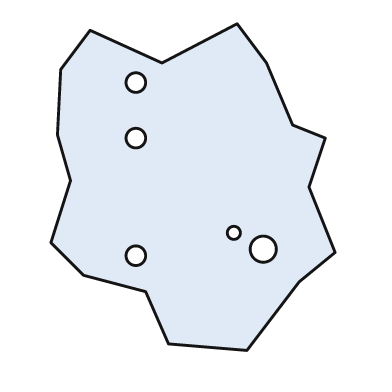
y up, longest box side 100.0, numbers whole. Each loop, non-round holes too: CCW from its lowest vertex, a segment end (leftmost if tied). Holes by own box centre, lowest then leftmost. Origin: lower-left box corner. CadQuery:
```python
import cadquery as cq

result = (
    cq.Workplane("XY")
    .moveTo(60.0, 0.0)
    .lineTo(76.0, 21.0)
    .lineTo(87.0, 30.0)
    .lineTo(79.0, 50.0)
    .lineTo(84.0, 65.0)
    .lineTo(74.0, 69.0)
    .lineTo(66.0, 88.0)
    .lineTo(57.0, 100.0)
    .lineTo(34.0, 88.0)
    .lineTo(12.0, 98.0)
    .lineTo(3.0, 86.0)
    .lineTo(2.0, 66.0)
    .lineTo(6.0, 52.0)
    .lineTo(0.0, 33.0)
    .lineTo(10.0, 23.0)
    .lineTo(29.0, 18.0)
    .lineTo(36.0, 2.0)
    .close()
    .moveTo(26.0, 29.0)
    .circle(3.0)
    .moveTo(65.0, 31.0)
    .circle(4.0)
    .moveTo(56.0, 36.0)
    .circle(2.0)
    .moveTo(26.0, 65.0)
    .circle(3.0)
    .moveTo(26.0, 82.0)
    .circle(3.0)
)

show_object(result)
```